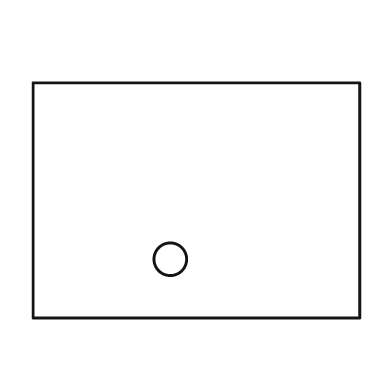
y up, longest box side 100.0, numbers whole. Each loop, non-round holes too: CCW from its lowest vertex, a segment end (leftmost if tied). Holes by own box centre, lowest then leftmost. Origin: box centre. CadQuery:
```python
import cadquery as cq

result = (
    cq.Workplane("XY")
    .moveTo(-50.0, -36.0)
    .lineTo(50.0, -36.0)
    .lineTo(50.0, 36.0)
    .lineTo(-50.0, 36.0)
    .close()
    .moveTo(-8.0, -18.0)
    .circle(5.0)
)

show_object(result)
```